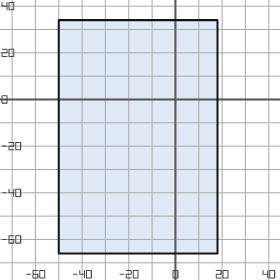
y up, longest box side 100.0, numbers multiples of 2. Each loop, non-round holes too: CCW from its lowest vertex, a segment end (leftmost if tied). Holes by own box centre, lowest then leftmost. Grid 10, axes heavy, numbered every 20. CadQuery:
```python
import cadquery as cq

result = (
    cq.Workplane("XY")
    .moveTo(-50.0, -66.0)
    .lineTo(18.0, -66.0)
    .lineTo(18.0, 34.0)
    .lineTo(-50.0, 34.0)
    .close()
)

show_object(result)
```